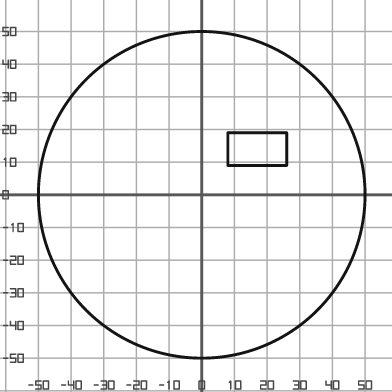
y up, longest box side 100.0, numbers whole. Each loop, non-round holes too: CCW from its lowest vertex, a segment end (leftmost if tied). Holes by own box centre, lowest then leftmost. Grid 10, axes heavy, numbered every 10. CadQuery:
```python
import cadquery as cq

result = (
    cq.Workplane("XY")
    .moveTo(0.0, 0.0)
    .circle(50.0)
    .moveTo(8.0, 9.0)
    .lineTo(26.0, 9.0)
    .lineTo(26.0, 19.0)
    .lineTo(8.0, 19.0)
    .close()
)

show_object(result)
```